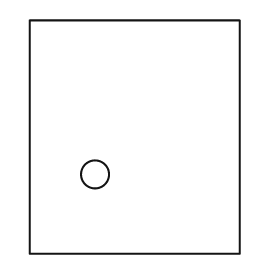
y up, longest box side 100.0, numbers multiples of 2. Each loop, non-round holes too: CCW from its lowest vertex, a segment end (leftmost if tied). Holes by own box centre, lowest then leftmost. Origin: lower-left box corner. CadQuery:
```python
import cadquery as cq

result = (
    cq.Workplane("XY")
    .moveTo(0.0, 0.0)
    .lineTo(90.0, 0.0)
    .lineTo(90.0, 100.0)
    .lineTo(0.0, 100.0)
    .close()
    .moveTo(28.0, 34.0)
    .circle(6.0)
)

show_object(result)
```